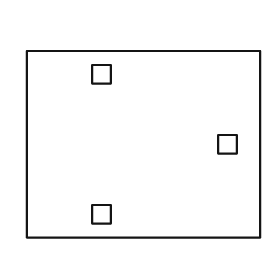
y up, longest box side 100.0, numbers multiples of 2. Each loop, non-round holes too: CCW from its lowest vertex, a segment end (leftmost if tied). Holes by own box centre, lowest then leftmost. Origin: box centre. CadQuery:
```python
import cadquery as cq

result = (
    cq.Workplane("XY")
    .moveTo(-50.0, -40.0)
    .lineTo(50.0, -40.0)
    .lineTo(50.0, 40.0)
    .lineTo(-50.0, 40.0)
    .close()
    .moveTo(-22.0, -34.0)
    .lineTo(-14.0, -34.0)
    .lineTo(-14.0, -26.0)
    .lineTo(-22.0, -26.0)
    .close()
    .moveTo(32.0, -4.0)
    .lineTo(40.0, -4.0)
    .lineTo(40.0, 4.0)
    .lineTo(32.0, 4.0)
    .close()
    .moveTo(-22.0, 26.0)
    .lineTo(-14.0, 26.0)
    .lineTo(-14.0, 34.0)
    .lineTo(-22.0, 34.0)
    .close()
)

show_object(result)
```